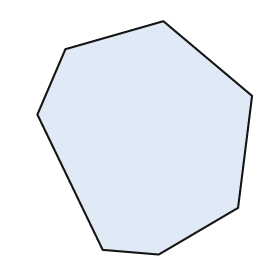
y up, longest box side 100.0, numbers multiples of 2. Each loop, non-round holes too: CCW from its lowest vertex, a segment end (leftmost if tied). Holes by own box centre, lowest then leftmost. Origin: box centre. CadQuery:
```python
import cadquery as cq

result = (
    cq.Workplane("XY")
    .moveTo(6.0, -50.0)
    .lineTo(40.0, -30.0)
    .lineTo(46.0, 18.0)
    .lineTo(8.0, 50.0)
    .lineTo(-34.0, 38.0)
    .lineTo(-46.0, 10.0)
    .lineTo(-18.0, -48.0)
    .close()
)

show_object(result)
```